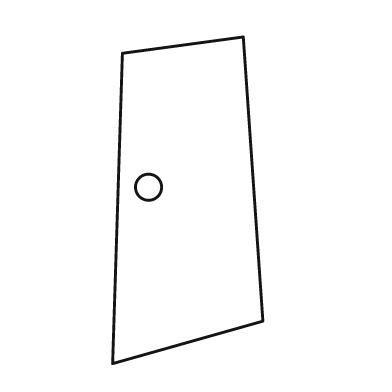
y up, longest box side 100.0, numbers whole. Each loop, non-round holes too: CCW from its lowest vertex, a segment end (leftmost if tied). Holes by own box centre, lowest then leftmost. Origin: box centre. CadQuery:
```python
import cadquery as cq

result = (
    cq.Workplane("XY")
    .moveTo(-23.0, -50.0)
    .lineTo(23.0, -37.0)
    .lineTo(17.0, 50.0)
    .lineTo(-20.0, 45.0)
    .close()
    .moveTo(-12.0, 4.0)
    .circle(4.0)
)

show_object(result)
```